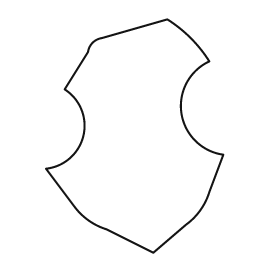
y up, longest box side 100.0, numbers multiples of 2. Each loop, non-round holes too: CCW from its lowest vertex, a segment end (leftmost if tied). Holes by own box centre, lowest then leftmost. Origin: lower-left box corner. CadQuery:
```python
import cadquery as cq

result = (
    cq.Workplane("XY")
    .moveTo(46.0, 0.0)
    .lineTo(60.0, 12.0)
    .threePointArc((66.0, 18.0), (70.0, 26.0))
    .lineTo(76.0, 42.0)
    .threePointArc((58.0, 60.0), (70.0, 82.0))
    .threePointArc((62.0, 92.0), (52.0, 100.0))
    .lineTo(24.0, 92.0)
    .threePointArc((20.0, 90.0), (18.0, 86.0))
    .lineTo(8.0, 70.0)
    .threePointArc((16.0, 50.0), (0.0, 36.0))
    .lineTo(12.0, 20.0)
    .threePointArc((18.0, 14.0), (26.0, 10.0))
    .close()
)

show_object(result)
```